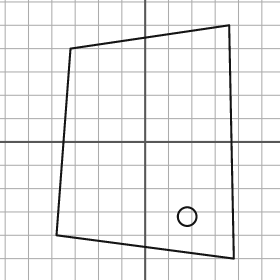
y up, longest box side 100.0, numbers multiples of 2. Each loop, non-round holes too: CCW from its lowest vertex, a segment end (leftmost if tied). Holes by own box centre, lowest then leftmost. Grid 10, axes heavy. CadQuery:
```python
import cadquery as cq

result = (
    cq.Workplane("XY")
    .moveTo(38.0, -50.0)
    .lineTo(36.0, 50.0)
    .lineTo(-32.0, 40.0)
    .lineTo(-38.0, -40.0)
    .close()
    .moveTo(18.0, -32.0)
    .circle(4.0)
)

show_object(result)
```